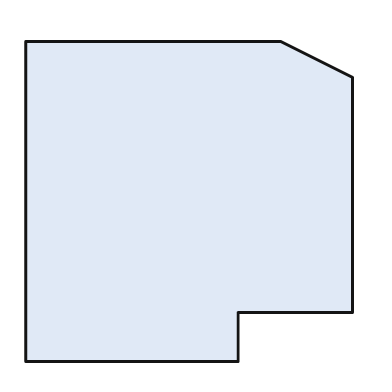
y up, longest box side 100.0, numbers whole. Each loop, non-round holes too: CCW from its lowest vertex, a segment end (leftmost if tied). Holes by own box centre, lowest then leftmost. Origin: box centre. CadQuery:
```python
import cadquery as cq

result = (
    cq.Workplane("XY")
    .moveTo(-50.0, -49.0)
    .lineTo(15.0, -49.0)
    .lineTo(15.0, -34.0)
    .lineTo(50.0, -34.0)
    .lineTo(50.0, 38.0)
    .lineTo(28.0, 49.0)
    .lineTo(-50.0, 49.0)
    .close()
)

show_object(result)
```